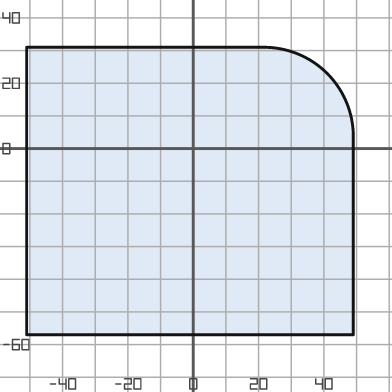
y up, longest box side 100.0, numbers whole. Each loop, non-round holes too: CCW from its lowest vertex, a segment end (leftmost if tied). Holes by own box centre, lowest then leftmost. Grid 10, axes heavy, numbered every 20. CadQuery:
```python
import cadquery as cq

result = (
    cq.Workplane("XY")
    .moveTo(-51.0, -57.0)
    .lineTo(49.0, -57.0)
    .lineTo(49.0, 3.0)
    .threePointArc((41.0, 23.0), (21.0, 31.0))
    .lineTo(-51.0, 31.0)
    .close()
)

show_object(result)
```